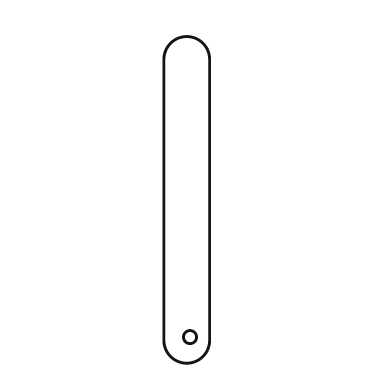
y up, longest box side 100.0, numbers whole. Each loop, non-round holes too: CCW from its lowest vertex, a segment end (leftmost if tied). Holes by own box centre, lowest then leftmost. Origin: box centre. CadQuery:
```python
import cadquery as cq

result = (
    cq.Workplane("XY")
    .moveTo(-7.0, -43.0)
    .threePointArc((0.0, -50.0), (7.0, -43.0))
    .lineTo(7.0, 43.0)
    .threePointArc((0.0, 50.0), (-7.0, 43.0))
    .close()
    .moveTo(1.0, -42.0)
    .circle(2.0)
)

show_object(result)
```